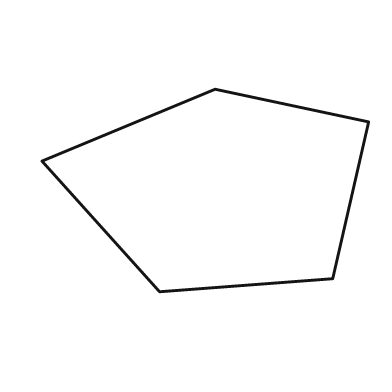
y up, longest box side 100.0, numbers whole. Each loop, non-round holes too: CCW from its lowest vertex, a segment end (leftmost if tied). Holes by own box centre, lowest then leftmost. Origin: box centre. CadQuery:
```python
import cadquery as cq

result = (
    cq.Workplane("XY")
    .moveTo(-14.0, -31.0)
    .lineTo(39.0, -27.0)
    .lineTo(50.0, 21.0)
    .lineTo(3.0, 31.0)
    .lineTo(-50.0, 9.0)
    .close()
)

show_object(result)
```